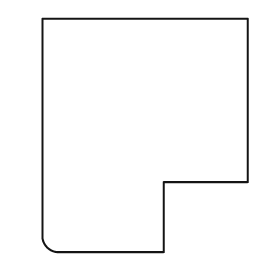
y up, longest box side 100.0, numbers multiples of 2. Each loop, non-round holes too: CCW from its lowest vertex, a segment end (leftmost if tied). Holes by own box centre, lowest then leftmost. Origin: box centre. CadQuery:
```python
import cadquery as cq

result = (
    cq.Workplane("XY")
    .moveTo(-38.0, -50.0)
    .lineTo(8.0, -50.0)
    .lineTo(8.0, -20.0)
    .lineTo(44.0, -20.0)
    .lineTo(44.0, 50.0)
    .lineTo(-44.0, 50.0)
    .lineTo(-44.0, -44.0)
    .threePointArc((-42.0, -48.0), (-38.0, -50.0))
    .close()
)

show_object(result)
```